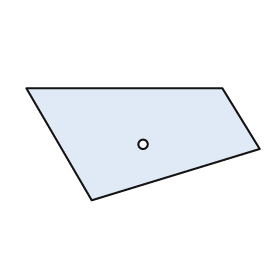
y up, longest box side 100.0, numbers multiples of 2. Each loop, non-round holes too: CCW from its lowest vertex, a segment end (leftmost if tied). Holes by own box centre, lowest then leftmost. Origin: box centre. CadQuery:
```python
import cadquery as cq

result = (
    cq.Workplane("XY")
    .moveTo(-22.0, -24.0)
    .lineTo(50.0, -2.0)
    .lineTo(34.0, 24.0)
    .lineTo(-50.0, 24.0)
    .close()
    .moveTo(0.0, 0.0)
    .circle(2.0)
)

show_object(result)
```